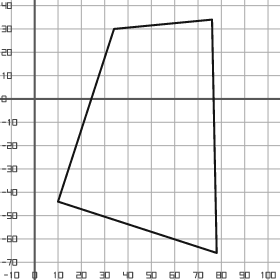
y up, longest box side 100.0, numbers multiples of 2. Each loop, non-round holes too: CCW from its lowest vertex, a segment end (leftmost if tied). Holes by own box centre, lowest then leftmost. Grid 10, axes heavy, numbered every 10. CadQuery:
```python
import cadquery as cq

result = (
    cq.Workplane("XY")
    .moveTo(78.0, -66.0)
    .lineTo(76.0, 34.0)
    .lineTo(34.0, 30.0)
    .lineTo(10.0, -44.0)
    .close()
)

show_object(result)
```